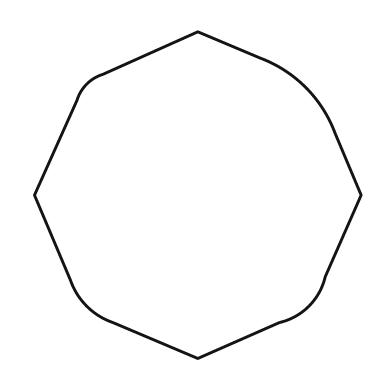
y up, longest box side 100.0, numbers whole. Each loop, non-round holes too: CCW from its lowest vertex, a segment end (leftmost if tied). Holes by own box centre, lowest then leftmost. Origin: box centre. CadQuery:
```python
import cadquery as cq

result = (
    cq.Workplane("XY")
    .moveTo(0.0, -50.0)
    .lineTo(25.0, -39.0)
    .threePointArc((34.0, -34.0), (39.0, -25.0))
    .lineTo(50.0, 0.0)
    .lineTo(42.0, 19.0)
    .threePointArc((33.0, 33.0), (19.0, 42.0))
    .lineTo(0.0, 50.0)
    .lineTo(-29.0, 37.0)
    .threePointArc((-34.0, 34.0), (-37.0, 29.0))
    .lineTo(-50.0, 0.0)
    .lineTo(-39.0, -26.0)
    .threePointArc((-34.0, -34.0), (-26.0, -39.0))
    .close()
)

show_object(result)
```